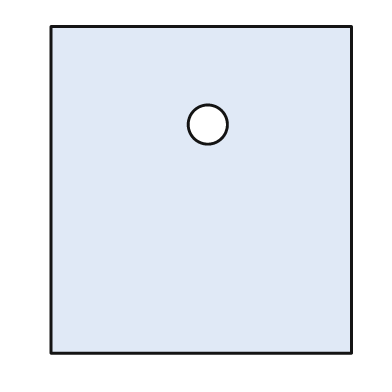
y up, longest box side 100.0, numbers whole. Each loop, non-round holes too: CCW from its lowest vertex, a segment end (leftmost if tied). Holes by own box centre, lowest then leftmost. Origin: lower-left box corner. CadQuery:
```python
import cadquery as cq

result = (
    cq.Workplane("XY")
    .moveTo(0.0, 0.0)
    .lineTo(92.0, 0.0)
    .lineTo(92.0, 100.0)
    .lineTo(0.0, 100.0)
    .close()
    .moveTo(48.0, 70.0)
    .circle(6.0)
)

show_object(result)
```